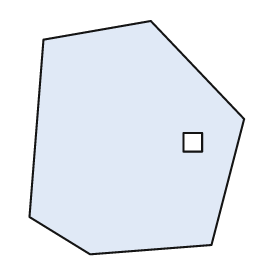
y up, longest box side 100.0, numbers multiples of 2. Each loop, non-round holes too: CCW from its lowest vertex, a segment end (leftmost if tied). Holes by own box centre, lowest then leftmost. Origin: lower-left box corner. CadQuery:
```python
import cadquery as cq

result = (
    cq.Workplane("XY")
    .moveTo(26.0, 0.0)
    .lineTo(78.0, 4.0)
    .lineTo(92.0, 58.0)
    .lineTo(52.0, 100.0)
    .lineTo(6.0, 92.0)
    .lineTo(0.0, 16.0)
    .close()
    .moveTo(66.0, 44.0)
    .lineTo(74.0, 44.0)
    .lineTo(74.0, 52.0)
    .lineTo(66.0, 52.0)
    .close()
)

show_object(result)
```